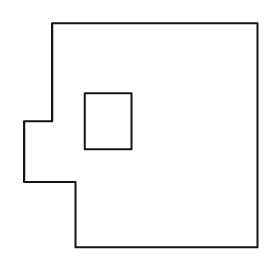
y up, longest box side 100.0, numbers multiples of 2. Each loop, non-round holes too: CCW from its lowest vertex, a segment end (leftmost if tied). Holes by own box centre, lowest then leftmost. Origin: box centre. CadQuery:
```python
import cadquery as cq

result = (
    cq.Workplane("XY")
    .moveTo(-28.0, -48.0)
    .lineTo(50.0, -48.0)
    .lineTo(50.0, 48.0)
    .lineTo(-38.0, 48.0)
    .lineTo(-38.0, 6.0)
    .lineTo(-50.0, 6.0)
    .lineTo(-50.0, -20.0)
    .lineTo(-28.0, -20.0)
    .close()
    .moveTo(-24.0, -6.0)
    .lineTo(-4.0, -6.0)
    .lineTo(-4.0, 18.0)
    .lineTo(-24.0, 18.0)
    .close()
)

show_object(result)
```